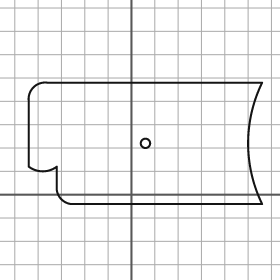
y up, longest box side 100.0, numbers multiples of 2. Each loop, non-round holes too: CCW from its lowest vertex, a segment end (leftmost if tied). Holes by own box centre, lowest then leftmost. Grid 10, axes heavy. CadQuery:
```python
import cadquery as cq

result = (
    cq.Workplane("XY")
    .moveTo(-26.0, -4.0)
    .lineTo(56.0, -4.0)
    .threePointArc((50.0, 22.0), (56.0, 48.0))
    .lineTo(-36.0, 48.0)
    .threePointArc((-42.0, 46.0), (-44.0, 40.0))
    .lineTo(-44.0, 12.0)
    .threePointArc((-38.0, 10.0), (-32.0, 12.0))
    .lineTo(-32.0, 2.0)
    .threePointArc((-30.0, -2.0), (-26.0, -4.0))
    .close()
    .moveTo(6.0, 22.0)
    .circle(2.0)
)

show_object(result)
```